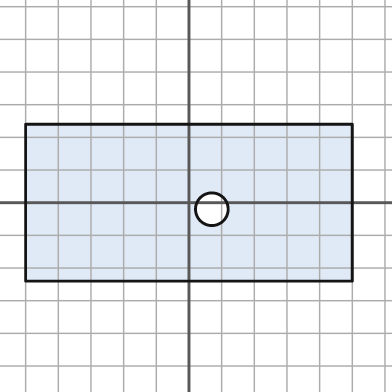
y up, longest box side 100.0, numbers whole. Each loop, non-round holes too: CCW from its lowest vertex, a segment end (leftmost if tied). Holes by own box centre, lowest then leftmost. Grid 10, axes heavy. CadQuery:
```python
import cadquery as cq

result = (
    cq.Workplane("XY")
    .moveTo(-50.0, -24.0)
    .lineTo(50.0, -24.0)
    .lineTo(50.0, 24.0)
    .lineTo(-50.0, 24.0)
    .close()
    .moveTo(7.0, -2.0)
    .circle(5.0)
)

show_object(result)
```